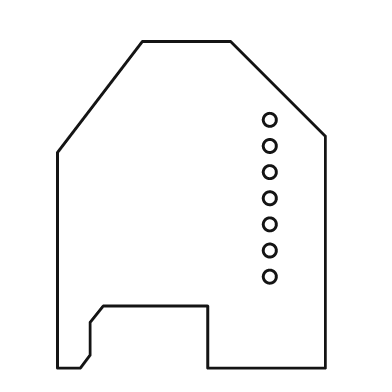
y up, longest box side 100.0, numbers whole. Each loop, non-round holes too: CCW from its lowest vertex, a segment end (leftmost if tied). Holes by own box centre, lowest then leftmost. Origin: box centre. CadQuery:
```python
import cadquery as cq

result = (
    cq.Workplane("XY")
    .moveTo(-41.0, -50.0)
    .lineTo(-34.0, -50.0)
    .lineTo(-31.0, -46.0)
    .lineTo(-31.0, -36.0)
    .lineTo(-27.0, -31.0)
    .lineTo(5.0, -31.0)
    .lineTo(5.0, -50.0)
    .lineTo(41.0, -50.0)
    .lineTo(41.0, 21.0)
    .lineTo(12.0, 50.0)
    .lineTo(-15.0, 50.0)
    .lineTo(-41.0, 16.0)
    .close()
    .moveTo(24.0, -22.0)
    .circle(2.0)
    .moveTo(24.0, -14.0)
    .circle(2.0)
    .moveTo(24.0, -6.0)
    .circle(2.0)
    .moveTo(24.0, 2.0)
    .circle(2.0)
    .moveTo(24.0, 10.0)
    .circle(2.0)
    .moveTo(24.0, 18.0)
    .circle(2.0)
    .moveTo(24.0, 26.0)
    .circle(2.0)
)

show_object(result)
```